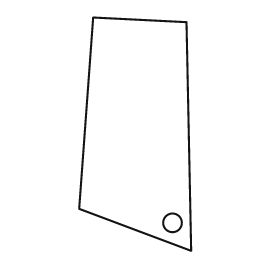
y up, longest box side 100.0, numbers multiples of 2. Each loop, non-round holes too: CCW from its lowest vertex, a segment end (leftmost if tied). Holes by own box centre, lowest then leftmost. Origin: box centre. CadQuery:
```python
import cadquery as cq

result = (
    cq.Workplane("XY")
    .moveTo(24.0, -50.0)
    .lineTo(22.0, 48.0)
    .lineTo(-18.0, 50.0)
    .lineTo(-24.0, -32.0)
    .close()
    .moveTo(16.0, -38.0)
    .circle(4.0)
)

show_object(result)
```